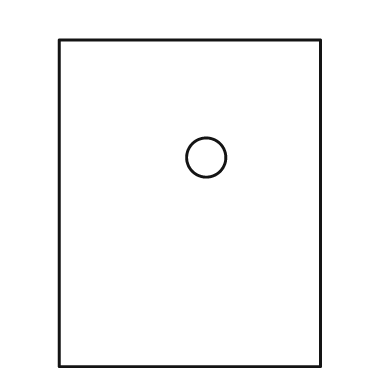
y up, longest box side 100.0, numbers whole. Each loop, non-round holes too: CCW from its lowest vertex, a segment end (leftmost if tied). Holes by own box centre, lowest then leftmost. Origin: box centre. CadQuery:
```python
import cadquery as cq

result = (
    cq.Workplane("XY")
    .moveTo(-40.0, -50.0)
    .lineTo(40.0, -50.0)
    .lineTo(40.0, 50.0)
    .lineTo(-40.0, 50.0)
    .close()
    .moveTo(5.0, 14.0)
    .circle(6.0)
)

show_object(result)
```